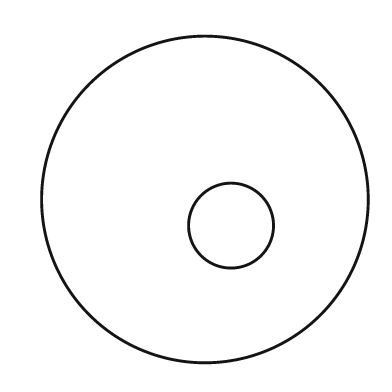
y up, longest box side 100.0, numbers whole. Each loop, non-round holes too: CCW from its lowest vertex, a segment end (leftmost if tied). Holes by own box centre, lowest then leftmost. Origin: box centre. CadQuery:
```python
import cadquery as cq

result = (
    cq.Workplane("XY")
    .moveTo(0.0, 0.0)
    .circle(50.0)
    .moveTo(8.0, -8.0)
    .circle(13.0)
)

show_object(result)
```